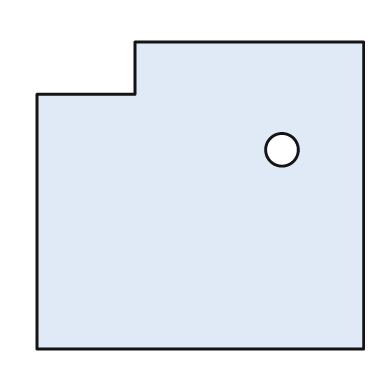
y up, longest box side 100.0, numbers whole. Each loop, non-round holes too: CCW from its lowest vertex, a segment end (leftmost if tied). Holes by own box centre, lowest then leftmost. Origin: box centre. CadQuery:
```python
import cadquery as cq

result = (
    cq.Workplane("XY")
    .moveTo(-50.0, -47.0)
    .lineTo(50.0, -47.0)
    .lineTo(50.0, 47.0)
    .lineTo(-20.0, 47.0)
    .lineTo(-20.0, 31.0)
    .lineTo(-50.0, 31.0)
    .close()
    .moveTo(25.0, 14.0)
    .circle(5.0)
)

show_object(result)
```